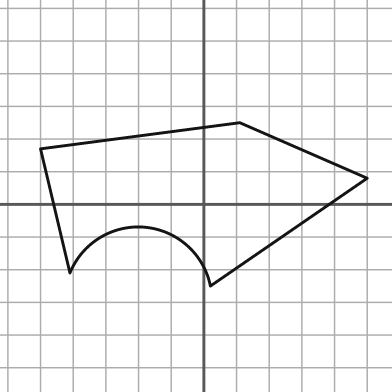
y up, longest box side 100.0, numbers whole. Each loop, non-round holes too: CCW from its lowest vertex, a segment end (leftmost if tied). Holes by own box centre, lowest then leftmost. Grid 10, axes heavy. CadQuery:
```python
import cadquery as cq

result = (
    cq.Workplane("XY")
    .moveTo(2.0, -25.0)
    .lineTo(50.0, 8.0)
    .lineTo(11.0, 25.0)
    .lineTo(-50.0, 17.0)
    .lineTo(-41.0, -21.0)
    .threePointArc((-18.0, -7.0), (2.0, -25.0))
    .close()
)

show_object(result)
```